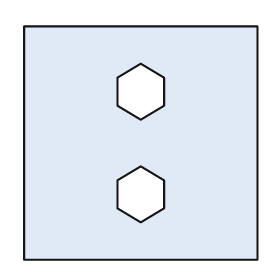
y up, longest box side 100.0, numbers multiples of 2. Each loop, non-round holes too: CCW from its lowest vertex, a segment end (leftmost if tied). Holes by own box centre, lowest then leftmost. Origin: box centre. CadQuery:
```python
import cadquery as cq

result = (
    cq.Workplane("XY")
    .moveTo(-50.0, -50.0)
    .lineTo(50.0, -50.0)
    .lineTo(50.0, 50.0)
    .lineTo(-50.0, 50.0)
    .close()
    .moveTo(0.0, -34.0)
    .lineTo(10.0, -28.0)
    .lineTo(10.0, -16.0)
    .lineTo(0.0, -10.0)
    .lineTo(-10.0, -16.0)
    .lineTo(-10.0, -28.0)
    .close()
    .moveTo(0.0, 10.0)
    .lineTo(10.0, 16.0)
    .lineTo(10.0, 28.0)
    .lineTo(0.0, 34.0)
    .lineTo(-10.0, 28.0)
    .lineTo(-10.0, 16.0)
    .close()
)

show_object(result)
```